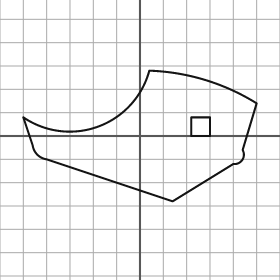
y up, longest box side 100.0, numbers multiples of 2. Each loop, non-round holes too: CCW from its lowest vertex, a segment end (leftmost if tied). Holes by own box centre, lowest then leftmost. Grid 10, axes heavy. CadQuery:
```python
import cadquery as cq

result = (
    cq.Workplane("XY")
    .moveTo(14.0, -28.0)
    .lineTo(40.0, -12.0)
    .threePointArc((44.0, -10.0), (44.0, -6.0))
    .lineTo(50.0, 14.0)
    .threePointArc((28.0, 24.0), (4.0, 28.0))
    .threePointArc((-18.0, 4.0), (-50.0, 8.0))
    .lineTo(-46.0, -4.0)
    .threePointArc((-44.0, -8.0), (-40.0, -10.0))
    .close()
    .moveTo(22.0, 0.0)
    .lineTo(30.0, 0.0)
    .lineTo(30.0, 8.0)
    .lineTo(22.0, 8.0)
    .close()
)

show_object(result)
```